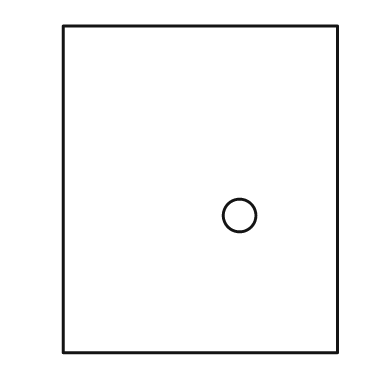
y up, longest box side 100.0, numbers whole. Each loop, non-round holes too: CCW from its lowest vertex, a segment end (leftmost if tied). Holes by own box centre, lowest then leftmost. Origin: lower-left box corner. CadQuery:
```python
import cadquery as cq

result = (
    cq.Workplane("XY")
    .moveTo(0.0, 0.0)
    .lineTo(84.0, 0.0)
    .lineTo(84.0, 100.0)
    .lineTo(0.0, 100.0)
    .close()
    .moveTo(54.0, 42.0)
    .circle(5.0)
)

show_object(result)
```